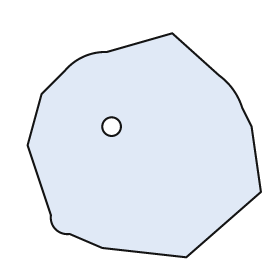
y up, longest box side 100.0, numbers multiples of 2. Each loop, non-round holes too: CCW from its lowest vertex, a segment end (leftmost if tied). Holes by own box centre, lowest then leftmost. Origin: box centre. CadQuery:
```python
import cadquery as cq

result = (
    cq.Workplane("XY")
    .moveTo(18.0, -48.0)
    .lineTo(50.0, -20.0)
    .lineTo(46.0, 8.0)
    .lineTo(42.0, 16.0)
    .threePointArc((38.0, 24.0), (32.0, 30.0))
    .lineTo(12.0, 48.0)
    .lineTo(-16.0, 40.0)
    .threePointArc((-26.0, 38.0), (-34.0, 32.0))
    .lineTo(-44.0, 22.0)
    .lineTo(-50.0, 0.0)
    .lineTo(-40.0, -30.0)
    .threePointArc((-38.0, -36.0), (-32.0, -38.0))
    .lineTo(-18.0, -44.0)
    .close()
    .moveTo(-14.0, 8.0)
    .circle(4.0)
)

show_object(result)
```